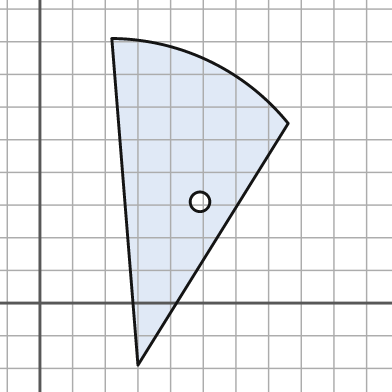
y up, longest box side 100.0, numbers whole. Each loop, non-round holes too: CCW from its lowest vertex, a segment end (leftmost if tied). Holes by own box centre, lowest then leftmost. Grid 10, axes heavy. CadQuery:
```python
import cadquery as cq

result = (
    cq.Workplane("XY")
    .moveTo(30.0, -19.0)
    .lineTo(76.0, 55.0)
    .threePointArc((52.0, 74.0), (22.0, 81.0))
    .close()
    .moveTo(49.0, 31.0)
    .circle(3.0)
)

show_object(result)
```